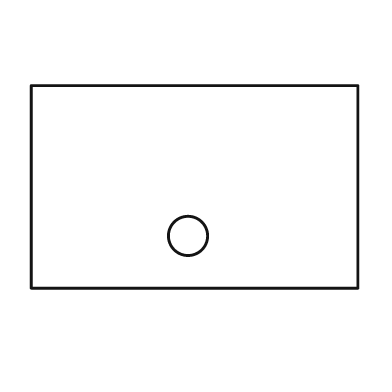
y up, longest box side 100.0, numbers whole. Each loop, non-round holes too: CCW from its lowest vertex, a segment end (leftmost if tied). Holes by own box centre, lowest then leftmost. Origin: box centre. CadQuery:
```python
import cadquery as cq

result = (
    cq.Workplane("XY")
    .moveTo(-50.0, -31.0)
    .lineTo(50.0, -31.0)
    .lineTo(50.0, 31.0)
    .lineTo(-50.0, 31.0)
    .close()
    .moveTo(-2.0, -15.0)
    .circle(6.0)
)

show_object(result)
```